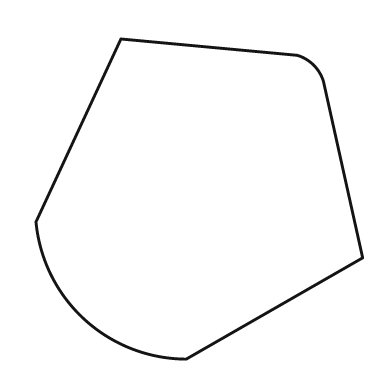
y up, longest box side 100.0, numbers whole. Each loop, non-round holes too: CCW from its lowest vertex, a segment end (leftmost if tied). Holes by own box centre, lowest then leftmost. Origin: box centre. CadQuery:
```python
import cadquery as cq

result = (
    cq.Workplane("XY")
    .moveTo(-4.0, -49.0)
    .lineTo(50.0, -18.0)
    .lineTo(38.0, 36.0)
    .threePointArc((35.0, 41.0), (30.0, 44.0))
    .lineTo(-24.0, 49.0)
    .lineTo(-50.0, -7.0)
    .threePointArc((-35.0, -37.0), (-4.0, -49.0))
    .close()
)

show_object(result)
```